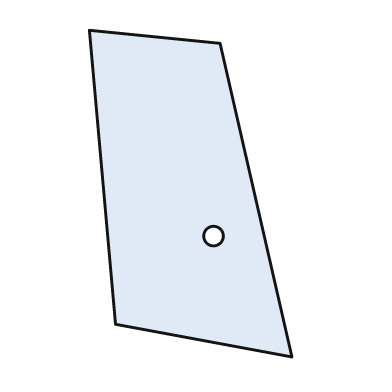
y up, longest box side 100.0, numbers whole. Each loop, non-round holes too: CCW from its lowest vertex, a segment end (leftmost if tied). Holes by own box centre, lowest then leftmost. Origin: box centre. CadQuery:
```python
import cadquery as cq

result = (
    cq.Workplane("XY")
    .moveTo(31.0, -50.0)
    .lineTo(9.0, 46.0)
    .lineTo(-31.0, 50.0)
    .lineTo(-23.0, -40.0)
    .close()
    .moveTo(7.0, -13.0)
    .circle(3.0)
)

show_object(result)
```